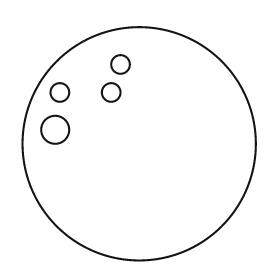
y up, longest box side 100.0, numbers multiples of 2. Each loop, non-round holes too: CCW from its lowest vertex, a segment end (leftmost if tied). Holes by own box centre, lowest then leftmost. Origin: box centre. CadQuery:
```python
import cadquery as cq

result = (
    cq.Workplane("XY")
    .moveTo(0.0, 0.0)
    .circle(50.0)
    .moveTo(-36.0, 6.0)
    .circle(6.0)
    .moveTo(-34.0, 22.0)
    .circle(4.0)
    .moveTo(-12.0, 22.0)
    .circle(4.0)
    .moveTo(-8.0, 34.0)
    .circle(4.0)
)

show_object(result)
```